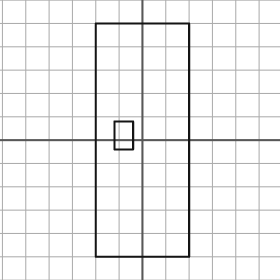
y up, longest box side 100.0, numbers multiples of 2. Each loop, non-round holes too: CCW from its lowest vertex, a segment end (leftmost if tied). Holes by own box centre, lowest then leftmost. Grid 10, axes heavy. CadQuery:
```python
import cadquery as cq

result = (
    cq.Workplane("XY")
    .moveTo(-20.0, -50.0)
    .lineTo(20.0, -50.0)
    .lineTo(20.0, 50.0)
    .lineTo(-20.0, 50.0)
    .close()
    .moveTo(-12.0, -4.0)
    .lineTo(-4.0, -4.0)
    .lineTo(-4.0, 8.0)
    .lineTo(-12.0, 8.0)
    .close()
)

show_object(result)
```